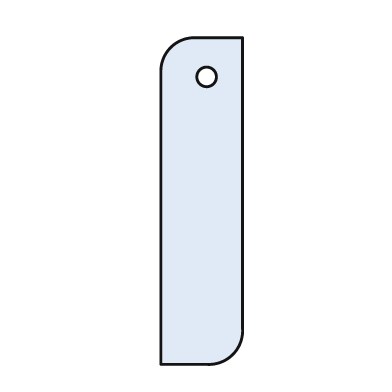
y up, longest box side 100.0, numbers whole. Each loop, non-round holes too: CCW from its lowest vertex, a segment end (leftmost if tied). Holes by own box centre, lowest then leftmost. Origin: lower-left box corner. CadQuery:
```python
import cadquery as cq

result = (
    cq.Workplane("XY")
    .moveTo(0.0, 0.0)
    .lineTo(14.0, 0.0)
    .threePointArc((22.0, 3.0), (25.0, 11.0))
    .lineTo(25.0, 100.0)
    .lineTo(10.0, 100.0)
    .threePointArc((3.0, 97.0), (0.0, 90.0))
    .close()
    .moveTo(14.0, 88.0)
    .circle(3.0)
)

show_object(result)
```